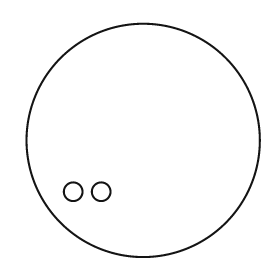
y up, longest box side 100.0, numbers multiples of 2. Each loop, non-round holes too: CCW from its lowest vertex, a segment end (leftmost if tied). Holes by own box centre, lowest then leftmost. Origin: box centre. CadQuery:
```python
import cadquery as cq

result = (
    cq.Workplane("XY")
    .moveTo(0.0, 0.0)
    .circle(50.0)
    .moveTo(-30.0, -22.0)
    .circle(4.0)
    .moveTo(-18.0, -22.0)
    .circle(4.0)
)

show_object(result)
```